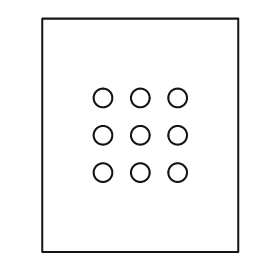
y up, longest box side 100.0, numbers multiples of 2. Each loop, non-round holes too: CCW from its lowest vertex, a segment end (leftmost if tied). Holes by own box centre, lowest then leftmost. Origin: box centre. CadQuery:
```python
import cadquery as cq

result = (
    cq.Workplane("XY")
    .moveTo(-42.0, -50.0)
    .lineTo(42.0, -50.0)
    .lineTo(42.0, 50.0)
    .lineTo(-42.0, 50.0)
    .close()
    .moveTo(-16.0, -16.0)
    .circle(4.0)
    .moveTo(0.0, -16.0)
    .circle(4.0)
    .moveTo(16.0, -16.0)
    .circle(4.0)
    .moveTo(-16.0, 0.0)
    .circle(4.0)
    .moveTo(0.0, 0.0)
    .circle(4.0)
    .moveTo(16.0, 0.0)
    .circle(4.0)
    .moveTo(-16.0, 16.0)
    .circle(4.0)
    .moveTo(0.0, 16.0)
    .circle(4.0)
    .moveTo(16.0, 16.0)
    .circle(4.0)
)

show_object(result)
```